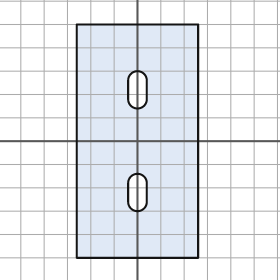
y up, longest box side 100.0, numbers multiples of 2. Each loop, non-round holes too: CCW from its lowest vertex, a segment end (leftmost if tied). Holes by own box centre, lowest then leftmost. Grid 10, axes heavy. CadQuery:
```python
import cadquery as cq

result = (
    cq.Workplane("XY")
    .moveTo(-26.0, -50.0)
    .lineTo(26.0, -50.0)
    .lineTo(26.0, 50.0)
    .lineTo(-26.0, 50.0)
    .close()
    .moveTo(-4.0, -26.0)
    .threePointArc((0.0, -30.0), (4.0, -26.0))
    .lineTo(4.0, -18.0)
    .threePointArc((0.0, -14.0), (-4.0, -18.0))
    .close()
    .moveTo(-4.0, 18.0)
    .threePointArc((0.0, 14.0), (4.0, 18.0))
    .lineTo(4.0, 26.0)
    .threePointArc((0.0, 30.0), (-4.0, 26.0))
    .close()
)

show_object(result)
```